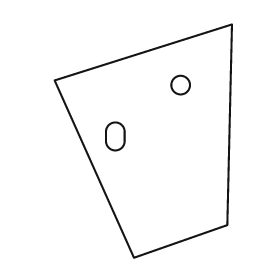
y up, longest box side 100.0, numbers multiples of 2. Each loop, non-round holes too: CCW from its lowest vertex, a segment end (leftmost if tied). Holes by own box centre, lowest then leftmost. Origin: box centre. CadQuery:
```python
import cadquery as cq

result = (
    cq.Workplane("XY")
    .moveTo(-4.0, -50.0)
    .lineTo(36.0, -36.0)
    .lineTo(38.0, 50.0)
    .lineTo(-38.0, 26.0)
    .close()
    .moveTo(-16.0, 0.0)
    .threePointArc((-12.0, -4.0), (-8.0, 0.0))
    .lineTo(-8.0, 4.0)
    .threePointArc((-12.0, 8.0), (-16.0, 4.0))
    .close()
    .moveTo(16.0, 24.0)
    .circle(4.0)
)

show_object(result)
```